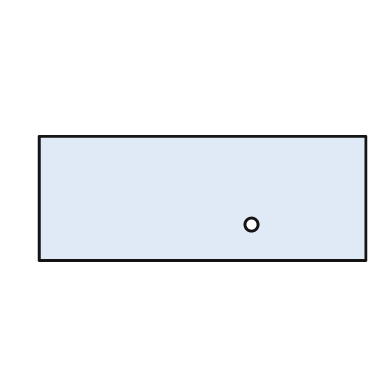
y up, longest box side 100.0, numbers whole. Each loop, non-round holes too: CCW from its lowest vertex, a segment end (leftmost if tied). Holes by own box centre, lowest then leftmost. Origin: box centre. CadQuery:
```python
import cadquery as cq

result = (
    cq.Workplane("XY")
    .moveTo(-50.0, -19.0)
    .lineTo(50.0, -19.0)
    .lineTo(50.0, 19.0)
    .lineTo(-50.0, 19.0)
    .close()
    .moveTo(15.0, -8.0)
    .circle(2.0)
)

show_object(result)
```